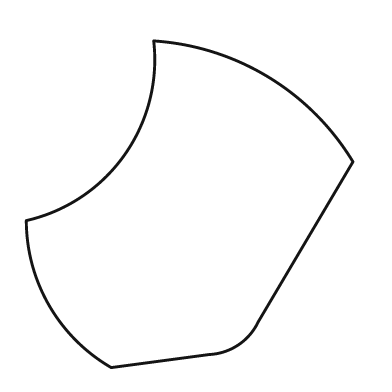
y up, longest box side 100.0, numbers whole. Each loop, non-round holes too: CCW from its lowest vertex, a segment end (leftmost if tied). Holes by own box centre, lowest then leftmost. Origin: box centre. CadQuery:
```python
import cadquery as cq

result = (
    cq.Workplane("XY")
    .moveTo(-24.0, -50.0)
    .lineTo(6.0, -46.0)
    .threePointArc((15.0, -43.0), (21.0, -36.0))
    .lineTo(50.0, 13.0)
    .threePointArc((24.0, 39.0), (-11.0, 50.0))
    .threePointArc((-20.0, 15.0), (-50.0, -5.0))
    .threePointArc((-43.0, -31.0), (-24.0, -50.0))
    .close()
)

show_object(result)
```